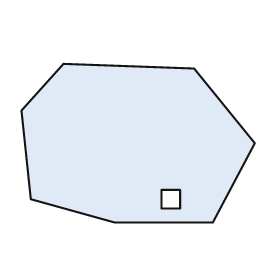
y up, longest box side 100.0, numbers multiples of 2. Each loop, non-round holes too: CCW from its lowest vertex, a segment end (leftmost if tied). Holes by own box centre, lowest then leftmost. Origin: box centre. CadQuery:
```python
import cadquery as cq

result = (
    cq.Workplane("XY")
    .moveTo(-10.0, -34.0)
    .lineTo(32.0, -34.0)
    .lineTo(50.0, 0.0)
    .lineTo(24.0, 32.0)
    .lineTo(-32.0, 34.0)
    .lineTo(-50.0, 14.0)
    .lineTo(-46.0, -24.0)
    .close()
    .moveTo(10.0, -28.0)
    .lineTo(18.0, -28.0)
    .lineTo(18.0, -20.0)
    .lineTo(10.0, -20.0)
    .close()
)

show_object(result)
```